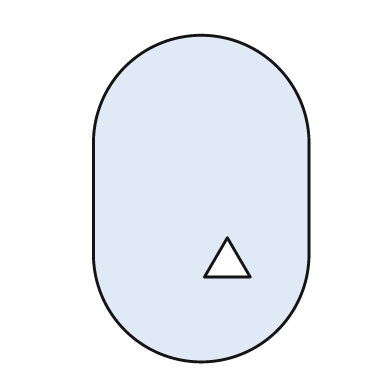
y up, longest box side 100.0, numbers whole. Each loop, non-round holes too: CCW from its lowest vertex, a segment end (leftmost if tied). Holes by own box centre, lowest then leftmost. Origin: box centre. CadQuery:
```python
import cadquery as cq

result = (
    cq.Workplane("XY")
    .moveTo(-33.0, -17.0)
    .threePointArc((0.0, -50.0), (33.0, -17.0))
    .lineTo(33.0, 17.0)
    .threePointArc((0.0, 50.0), (-33.0, 17.0))
    .close()
    .moveTo(1.0, -24.0)
    .lineTo(15.0, -24.0)
    .lineTo(8.0, -12.0)
    .close()
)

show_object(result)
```